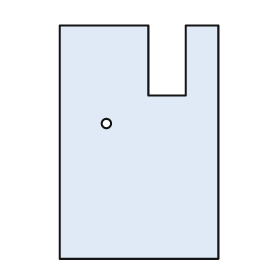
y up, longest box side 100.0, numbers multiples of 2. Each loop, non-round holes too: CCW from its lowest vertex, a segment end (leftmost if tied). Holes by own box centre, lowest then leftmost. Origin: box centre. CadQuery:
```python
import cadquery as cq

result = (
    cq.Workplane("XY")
    .moveTo(-34.0, -50.0)
    .lineTo(34.0, -50.0)
    .lineTo(34.0, 50.0)
    .lineTo(20.0, 50.0)
    .lineTo(20.0, 20.0)
    .lineTo(4.0, 20.0)
    .lineTo(4.0, 50.0)
    .lineTo(-34.0, 50.0)
    .close()
    .moveTo(-14.0, 8.0)
    .circle(2.0)
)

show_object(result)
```